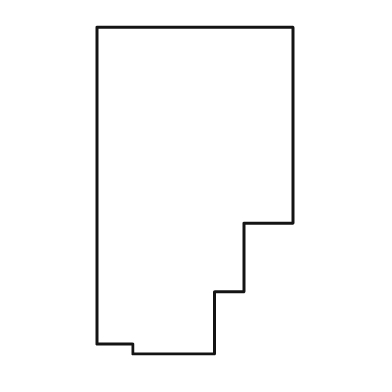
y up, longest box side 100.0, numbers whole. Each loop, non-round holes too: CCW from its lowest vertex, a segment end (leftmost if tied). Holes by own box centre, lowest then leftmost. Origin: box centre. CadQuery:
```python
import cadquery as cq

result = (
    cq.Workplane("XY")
    .moveTo(-19.0, -50.0)
    .lineTo(6.0, -50.0)
    .lineTo(6.0, -31.0)
    .lineTo(15.0, -31.0)
    .lineTo(15.0, -10.0)
    .lineTo(30.0, -10.0)
    .lineTo(30.0, 50.0)
    .lineTo(-30.0, 50.0)
    .lineTo(-30.0, -47.0)
    .lineTo(-19.0, -47.0)
    .close()
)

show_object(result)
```